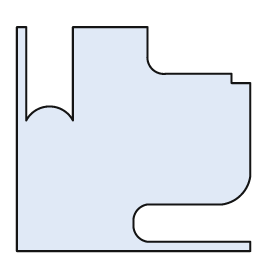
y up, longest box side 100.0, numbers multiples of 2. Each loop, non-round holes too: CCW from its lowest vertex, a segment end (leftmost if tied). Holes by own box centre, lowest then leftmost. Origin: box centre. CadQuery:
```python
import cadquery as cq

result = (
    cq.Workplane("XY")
    .moveTo(-50.0, -48.0)
    .lineTo(50.0, -48.0)
    .lineTo(50.0, -44.0)
    .lineTo(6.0, -44.0)
    .threePointArc((2.0, -42.0), (0.0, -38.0))
    .lineTo(0.0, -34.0)
    .threePointArc((2.0, -30.0), (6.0, -28.0))
    .lineTo(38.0, -28.0)
    .threePointArc((46.0, -24.0), (50.0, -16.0))
    .lineTo(50.0, 24.0)
    .lineTo(42.0, 24.0)
    .lineTo(42.0, 28.0)
    .lineTo(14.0, 28.0)
    .threePointArc((8.0, 30.0), (6.0, 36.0))
    .lineTo(6.0, 48.0)
    .lineTo(-26.0, 48.0)
    .lineTo(-26.0, 8.0)
    .threePointArc((-36.0, 14.0), (-46.0, 8.0))
    .lineTo(-46.0, 48.0)
    .lineTo(-50.0, 48.0)
    .close()
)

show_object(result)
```